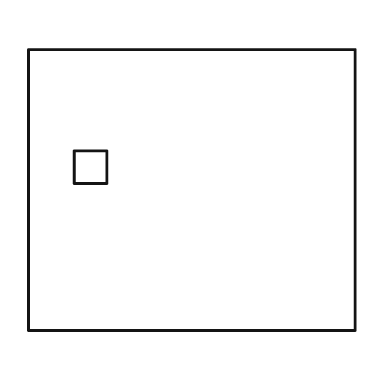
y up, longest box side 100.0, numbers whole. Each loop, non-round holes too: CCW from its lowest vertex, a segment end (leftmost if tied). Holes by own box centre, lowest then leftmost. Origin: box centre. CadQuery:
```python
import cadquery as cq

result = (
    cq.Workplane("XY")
    .moveTo(-50.0, -43.0)
    .lineTo(50.0, -43.0)
    .lineTo(50.0, 43.0)
    .lineTo(-50.0, 43.0)
    .close()
    .moveTo(-36.0, 2.0)
    .lineTo(-26.0, 2.0)
    .lineTo(-26.0, 12.0)
    .lineTo(-36.0, 12.0)
    .close()
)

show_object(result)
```